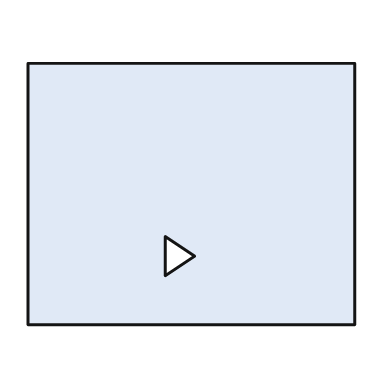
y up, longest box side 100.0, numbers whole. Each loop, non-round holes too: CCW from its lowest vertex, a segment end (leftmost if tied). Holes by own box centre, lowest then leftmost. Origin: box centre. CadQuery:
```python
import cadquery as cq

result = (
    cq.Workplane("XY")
    .moveTo(-50.0, -40.0)
    .lineTo(50.0, -40.0)
    .lineTo(50.0, 40.0)
    .lineTo(-50.0, 40.0)
    .close()
    .moveTo(-8.0, -25.0)
    .lineTo(1.0, -19.0)
    .lineTo(-8.0, -13.0)
    .close()
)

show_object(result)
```